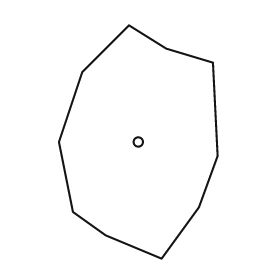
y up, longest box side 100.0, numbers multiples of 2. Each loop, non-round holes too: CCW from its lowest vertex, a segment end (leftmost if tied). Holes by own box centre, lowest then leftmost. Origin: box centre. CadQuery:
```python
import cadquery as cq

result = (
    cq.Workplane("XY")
    .moveTo(10.0, -50.0)
    .lineTo(26.0, -28.0)
    .lineTo(34.0, -6.0)
    .lineTo(32.0, 34.0)
    .lineTo(12.0, 40.0)
    .lineTo(-4.0, 50.0)
    .lineTo(-24.0, 30.0)
    .lineTo(-34.0, 0.0)
    .lineTo(-28.0, -30.0)
    .lineTo(-14.0, -40.0)
    .close()
    .moveTo(0.0, 0.0)
    .circle(2.0)
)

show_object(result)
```